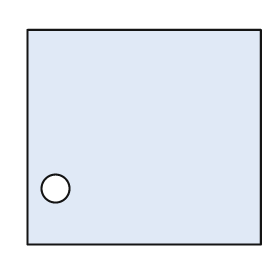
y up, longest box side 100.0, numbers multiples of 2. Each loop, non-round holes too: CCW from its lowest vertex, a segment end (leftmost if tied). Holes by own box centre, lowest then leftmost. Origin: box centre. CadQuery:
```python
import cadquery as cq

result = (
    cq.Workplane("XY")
    .moveTo(-50.0, -46.0)
    .lineTo(50.0, -46.0)
    .lineTo(50.0, 46.0)
    .lineTo(-50.0, 46.0)
    .close()
    .moveTo(-38.0, -22.0)
    .circle(6.0)
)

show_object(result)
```